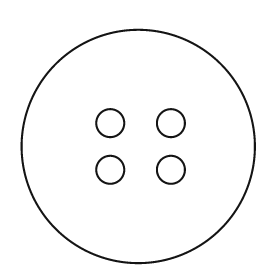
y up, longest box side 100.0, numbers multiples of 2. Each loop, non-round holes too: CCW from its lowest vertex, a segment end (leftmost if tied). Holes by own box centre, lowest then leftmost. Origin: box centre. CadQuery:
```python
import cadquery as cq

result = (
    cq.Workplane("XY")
    .moveTo(0.0, 0.0)
    .circle(50.0)
    .moveTo(-12.0, -10.0)
    .circle(6.0)
    .moveTo(14.0, -10.0)
    .circle(6.0)
    .moveTo(-12.0, 10.0)
    .circle(6.0)
    .moveTo(14.0, 10.0)
    .circle(6.0)
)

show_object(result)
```